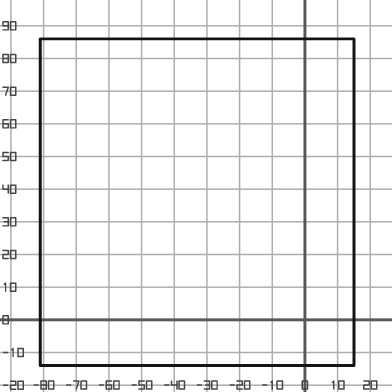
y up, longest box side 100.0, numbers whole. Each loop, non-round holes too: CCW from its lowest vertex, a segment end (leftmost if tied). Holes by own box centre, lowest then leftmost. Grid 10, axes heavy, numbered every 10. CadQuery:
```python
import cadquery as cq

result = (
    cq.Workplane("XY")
    .moveTo(-81.0, -14.0)
    .lineTo(15.0, -14.0)
    .lineTo(15.0, 86.0)
    .lineTo(-81.0, 86.0)
    .close()
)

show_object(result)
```